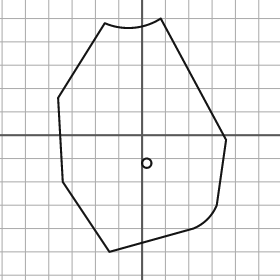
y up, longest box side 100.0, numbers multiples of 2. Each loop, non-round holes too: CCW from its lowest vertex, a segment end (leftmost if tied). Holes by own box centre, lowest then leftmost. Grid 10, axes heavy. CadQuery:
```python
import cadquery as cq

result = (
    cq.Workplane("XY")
    .moveTo(-14.0, -50.0)
    .lineTo(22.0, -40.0)
    .threePointArc((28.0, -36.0), (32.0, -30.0))
    .lineTo(36.0, -2.0)
    .lineTo(8.0, 50.0)
    .threePointArc((-4.0, 46.0), (-16.0, 48.0))
    .lineTo(-36.0, 16.0)
    .lineTo(-34.0, -20.0)
    .close()
    .moveTo(2.0, -12.0)
    .circle(2.0)
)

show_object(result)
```